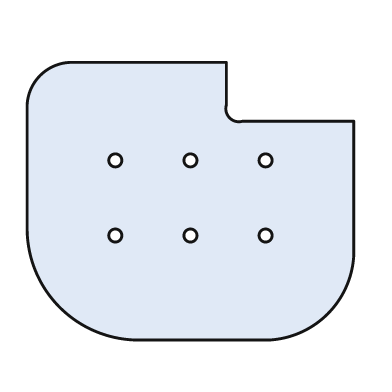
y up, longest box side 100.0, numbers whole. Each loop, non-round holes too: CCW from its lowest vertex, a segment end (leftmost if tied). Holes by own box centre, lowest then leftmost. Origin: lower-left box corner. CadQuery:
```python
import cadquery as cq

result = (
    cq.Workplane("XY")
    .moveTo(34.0, 0.0)
    .lineTo(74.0, 0.0)
    .threePointArc((92.0, 8.0), (100.0, 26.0))
    .lineTo(100.0, 67.0)
    .lineTo(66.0, 67.0)
    .threePointArc((62.0, 68.0), (61.0, 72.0))
    .lineTo(61.0, 85.0)
    .lineTo(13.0, 85.0)
    .threePointArc((4.0, 81.0), (0.0, 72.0))
    .lineTo(0.0, 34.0)
    .threePointArc((10.0, 10.0), (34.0, 0.0))
    .close()
    .moveTo(27.0, 32.0)
    .circle(2.0)
    .moveTo(50.0, 32.0)
    .circle(2.0)
    .moveTo(73.0, 32.0)
    .circle(2.0)
    .moveTo(27.0, 55.0)
    .circle(2.0)
    .moveTo(50.0, 55.0)
    .circle(2.0)
    .moveTo(73.0, 55.0)
    .circle(2.0)
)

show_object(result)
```